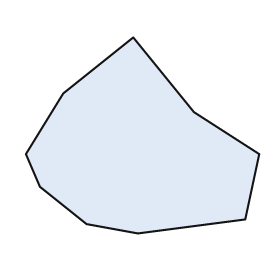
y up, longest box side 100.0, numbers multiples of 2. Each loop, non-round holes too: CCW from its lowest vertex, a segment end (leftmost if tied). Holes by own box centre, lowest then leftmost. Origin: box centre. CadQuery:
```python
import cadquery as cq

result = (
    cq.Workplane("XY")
    .moveTo(-2.0, -42.0)
    .lineTo(44.0, -36.0)
    .lineTo(50.0, -8.0)
    .lineTo(22.0, 10.0)
    .lineTo(-4.0, 42.0)
    .lineTo(-34.0, 18.0)
    .lineTo(-50.0, -8.0)
    .lineTo(-44.0, -22.0)
    .lineTo(-24.0, -38.0)
    .close()
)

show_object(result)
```